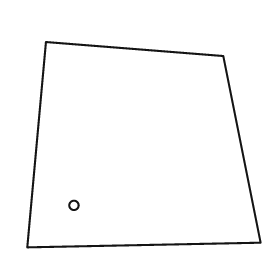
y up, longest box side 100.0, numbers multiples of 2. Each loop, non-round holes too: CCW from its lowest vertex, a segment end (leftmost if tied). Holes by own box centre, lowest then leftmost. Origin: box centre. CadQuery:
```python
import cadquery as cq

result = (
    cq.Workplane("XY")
    .moveTo(-50.0, -44.0)
    .lineTo(50.0, -42.0)
    .lineTo(34.0, 38.0)
    .lineTo(-42.0, 44.0)
    .close()
    .moveTo(-30.0, -26.0)
    .circle(2.0)
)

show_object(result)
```